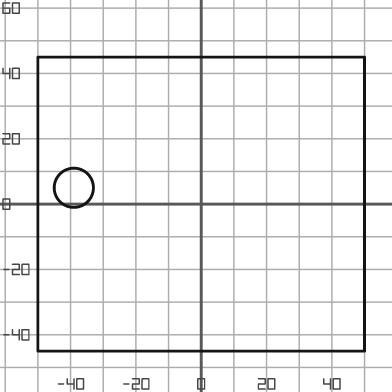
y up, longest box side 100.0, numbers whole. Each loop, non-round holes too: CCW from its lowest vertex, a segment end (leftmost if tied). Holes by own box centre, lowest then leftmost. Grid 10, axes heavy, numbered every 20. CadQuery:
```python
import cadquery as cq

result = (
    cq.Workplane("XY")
    .moveTo(-50.0, -45.0)
    .lineTo(50.0, -45.0)
    .lineTo(50.0, 45.0)
    .lineTo(-50.0, 45.0)
    .close()
    .moveTo(-39.0, 5.0)
    .circle(6.0)
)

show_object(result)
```